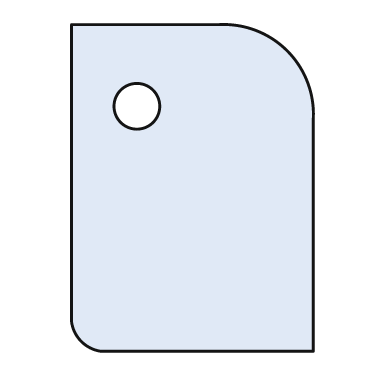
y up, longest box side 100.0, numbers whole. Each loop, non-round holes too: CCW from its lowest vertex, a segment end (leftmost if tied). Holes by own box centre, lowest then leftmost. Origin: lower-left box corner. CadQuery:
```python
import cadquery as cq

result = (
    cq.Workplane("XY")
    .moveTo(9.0, 0.0)
    .lineTo(74.0, 0.0)
    .lineTo(74.0, 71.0)
    .threePointArc((66.0, 92.0), (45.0, 100.0))
    .lineTo(0.0, 100.0)
    .lineTo(0.0, 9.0)
    .threePointArc((3.0, 3.0), (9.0, 0.0))
    .close()
    .moveTo(20.0, 75.0)
    .circle(7.0)
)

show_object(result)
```